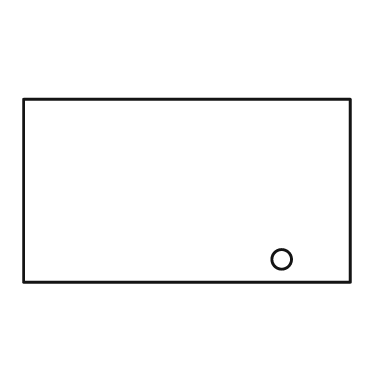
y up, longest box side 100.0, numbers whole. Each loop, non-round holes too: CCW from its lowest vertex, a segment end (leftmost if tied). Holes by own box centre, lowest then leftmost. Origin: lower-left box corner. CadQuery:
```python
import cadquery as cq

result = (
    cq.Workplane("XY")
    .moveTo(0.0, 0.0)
    .lineTo(100.0, 0.0)
    .lineTo(100.0, 56.0)
    .lineTo(0.0, 56.0)
    .close()
    .moveTo(79.0, 7.0)
    .circle(3.0)
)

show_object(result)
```